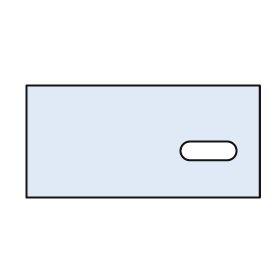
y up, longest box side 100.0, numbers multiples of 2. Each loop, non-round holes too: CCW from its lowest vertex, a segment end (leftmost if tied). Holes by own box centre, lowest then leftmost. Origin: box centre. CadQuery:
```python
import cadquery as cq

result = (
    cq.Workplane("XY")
    .moveTo(-50.0, -24.0)
    .lineTo(50.0, -24.0)
    .lineTo(50.0, 24.0)
    .lineTo(-50.0, 24.0)
    .close()
    .moveTo(20.0, -8.0)
    .lineTo(36.0, -8.0)
    .threePointArc((40.0, -4.0), (36.0, 0.0))
    .lineTo(20.0, 0.0)
    .threePointArc((16.0, -4.0), (20.0, -8.0))
    .close()
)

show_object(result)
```